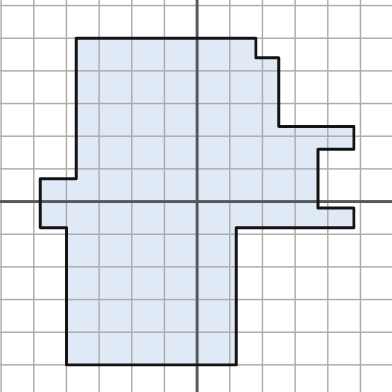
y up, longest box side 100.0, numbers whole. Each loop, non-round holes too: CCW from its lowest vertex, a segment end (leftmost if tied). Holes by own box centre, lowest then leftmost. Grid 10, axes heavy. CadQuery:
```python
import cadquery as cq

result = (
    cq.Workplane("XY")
    .moveTo(-40.0, -50.0)
    .lineTo(12.0, -50.0)
    .lineTo(12.0, -8.0)
    .lineTo(48.0, -8.0)
    .lineTo(48.0, -2.0)
    .lineTo(37.0, -2.0)
    .lineTo(37.0, 16.0)
    .lineTo(48.0, 16.0)
    .lineTo(48.0, 23.0)
    .lineTo(25.0, 23.0)
    .lineTo(25.0, 44.0)
    .lineTo(18.0, 44.0)
    .lineTo(18.0, 50.0)
    .lineTo(-37.0, 50.0)
    .lineTo(-37.0, 7.0)
    .lineTo(-48.0, 7.0)
    .lineTo(-48.0, -8.0)
    .lineTo(-40.0, -8.0)
    .close()
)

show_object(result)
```